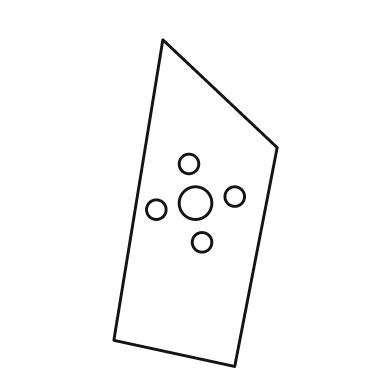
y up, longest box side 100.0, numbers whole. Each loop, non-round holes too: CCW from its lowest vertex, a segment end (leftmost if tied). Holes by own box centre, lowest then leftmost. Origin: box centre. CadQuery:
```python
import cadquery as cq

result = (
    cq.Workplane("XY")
    .moveTo(12.0, -50.0)
    .lineTo(25.0, 17.0)
    .lineTo(-10.0, 50.0)
    .lineTo(-25.0, -42.0)
    .close()
    .moveTo(2.0, -12.0)
    .circle(3.0)
    .moveTo(-12.0, -2.0)
    .circle(3.0)
    .moveTo(0.0, 0.0)
    .circle(5.0)
    .moveTo(12.0, 2.0)
    .circle(3.0)
    .moveTo(-2.0, 12.0)
    .circle(3.0)
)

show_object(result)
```